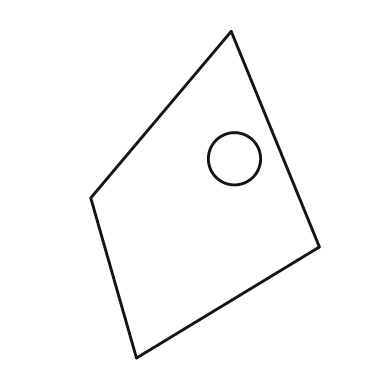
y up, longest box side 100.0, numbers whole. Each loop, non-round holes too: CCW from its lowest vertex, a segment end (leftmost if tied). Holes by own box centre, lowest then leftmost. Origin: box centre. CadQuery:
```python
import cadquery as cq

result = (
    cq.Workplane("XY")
    .moveTo(-21.0, -50.0)
    .lineTo(35.0, -16.0)
    .lineTo(8.0, 50.0)
    .lineTo(-35.0, -1.0)
    .close()
    .moveTo(9.0, 11.0)
    .circle(8.0)
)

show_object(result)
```